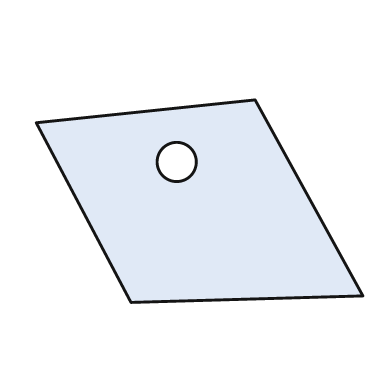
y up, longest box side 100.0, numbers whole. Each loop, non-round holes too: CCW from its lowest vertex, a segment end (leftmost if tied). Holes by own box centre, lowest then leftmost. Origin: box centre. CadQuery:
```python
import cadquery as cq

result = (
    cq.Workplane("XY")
    .moveTo(-21.0, -31.0)
    .lineTo(50.0, -29.0)
    .lineTo(17.0, 31.0)
    .lineTo(-50.0, 24.0)
    .close()
    .moveTo(-7.0, 12.0)
    .circle(6.0)
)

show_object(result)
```